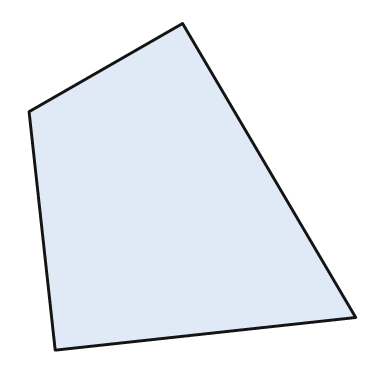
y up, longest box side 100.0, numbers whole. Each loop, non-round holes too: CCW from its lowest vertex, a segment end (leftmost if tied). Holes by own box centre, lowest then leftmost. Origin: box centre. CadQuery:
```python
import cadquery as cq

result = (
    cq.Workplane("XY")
    .moveTo(-42.0, -50.0)
    .lineTo(50.0, -40.0)
    .lineTo(-3.0, 50.0)
    .lineTo(-50.0, 23.0)
    .close()
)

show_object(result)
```